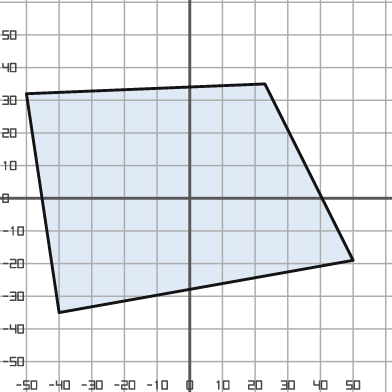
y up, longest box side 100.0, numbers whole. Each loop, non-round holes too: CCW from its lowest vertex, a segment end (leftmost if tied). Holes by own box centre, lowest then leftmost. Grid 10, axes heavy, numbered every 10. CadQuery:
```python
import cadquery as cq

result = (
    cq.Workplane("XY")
    .moveTo(-40.0, -35.0)
    .lineTo(50.0, -19.0)
    .lineTo(23.0, 35.0)
    .lineTo(-50.0, 32.0)
    .close()
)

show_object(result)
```